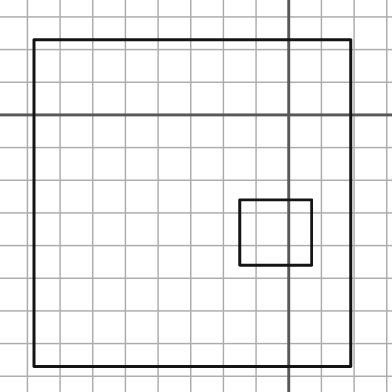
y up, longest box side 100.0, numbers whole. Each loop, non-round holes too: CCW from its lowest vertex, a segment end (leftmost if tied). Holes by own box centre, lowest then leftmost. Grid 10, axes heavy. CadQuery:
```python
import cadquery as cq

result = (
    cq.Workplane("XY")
    .moveTo(-78.0, -77.0)
    .lineTo(19.0, -77.0)
    .lineTo(19.0, 23.0)
    .lineTo(-78.0, 23.0)
    .close()
    .moveTo(-15.0, -46.0)
    .lineTo(7.0, -46.0)
    .lineTo(7.0, -26.0)
    .lineTo(-15.0, -26.0)
    .close()
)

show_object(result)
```